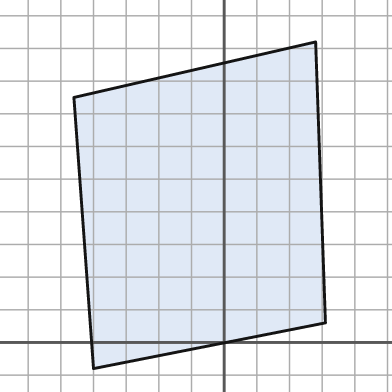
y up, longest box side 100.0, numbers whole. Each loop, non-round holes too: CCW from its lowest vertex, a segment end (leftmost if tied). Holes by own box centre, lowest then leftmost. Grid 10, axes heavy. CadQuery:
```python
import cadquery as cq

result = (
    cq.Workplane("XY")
    .moveTo(-40.0, -8.0)
    .lineTo(31.0, 6.0)
    .lineTo(28.0, 92.0)
    .lineTo(-46.0, 75.0)
    .close()
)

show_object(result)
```